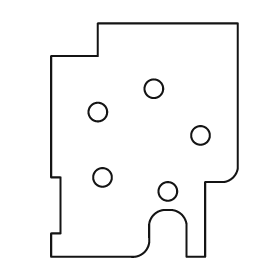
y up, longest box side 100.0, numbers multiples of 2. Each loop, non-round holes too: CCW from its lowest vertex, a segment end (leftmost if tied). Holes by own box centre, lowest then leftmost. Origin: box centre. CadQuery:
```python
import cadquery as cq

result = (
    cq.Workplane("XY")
    .moveTo(-40.0, -50.0)
    .lineTo(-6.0, -50.0)
    .threePointArc((0.0, -48.0), (2.0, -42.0))
    .lineTo(2.0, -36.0)
    .threePointArc((4.0, -32.0), (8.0, -30.0))
    .lineTo(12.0, -30.0)
    .threePointArc((16.0, -32.0), (18.0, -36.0))
    .lineTo(18.0, -50.0)
    .lineTo(26.0, -50.0)
    .lineTo(26.0, -18.0)
    .lineTo(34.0, -18.0)
    .threePointArc((38.0, -16.0), (40.0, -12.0))
    .lineTo(40.0, 50.0)
    .lineTo(-20.0, 50.0)
    .lineTo(-20.0, 36.0)
    .lineTo(-40.0, 36.0)
    .lineTo(-40.0, -16.0)
    .lineTo(-36.0, -16.0)
    .lineTo(-36.0, -40.0)
    .lineTo(-40.0, -40.0)
    .close()
    .moveTo(10.0, -22.0)
    .circle(4.0)
    .moveTo(-18.0, -16.0)
    .circle(4.0)
    .moveTo(24.0, 2.0)
    .circle(4.0)
    .moveTo(-20.0, 12.0)
    .circle(4.0)
    .moveTo(4.0, 22.0)
    .circle(4.0)
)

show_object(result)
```